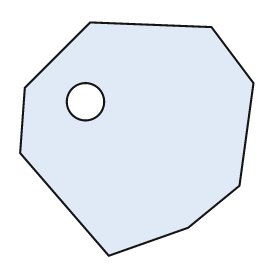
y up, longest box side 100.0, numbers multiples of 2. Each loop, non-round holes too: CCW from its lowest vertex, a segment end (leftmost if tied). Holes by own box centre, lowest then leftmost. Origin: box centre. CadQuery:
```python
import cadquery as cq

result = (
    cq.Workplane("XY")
    .moveTo(-12.0, -50.0)
    .lineTo(22.0, -38.0)
    .lineTo(44.0, -20.0)
    .lineTo(50.0, 24.0)
    .lineTo(32.0, 48.0)
    .lineTo(-20.0, 50.0)
    .lineTo(-48.0, 22.0)
    .lineTo(-50.0, -6.0)
    .close()
    .moveTo(-22.0, 16.0)
    .circle(8.0)
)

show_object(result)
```